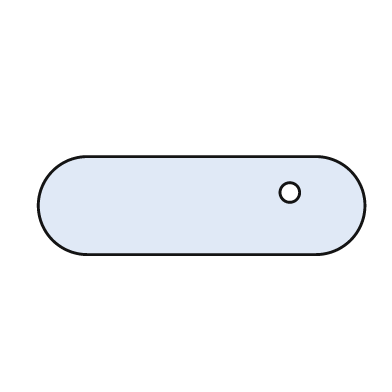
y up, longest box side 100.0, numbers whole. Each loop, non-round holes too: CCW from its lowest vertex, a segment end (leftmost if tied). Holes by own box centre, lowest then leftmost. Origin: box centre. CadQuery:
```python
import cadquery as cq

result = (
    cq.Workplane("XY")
    .moveTo(-35.0, -15.0)
    .lineTo(35.0, -15.0)
    .threePointArc((50.0, 0.0), (35.0, 15.0))
    .lineTo(-35.0, 15.0)
    .threePointArc((-50.0, 0.0), (-35.0, -15.0))
    .close()
    .moveTo(27.0, 4.0)
    .circle(3.0)
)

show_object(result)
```